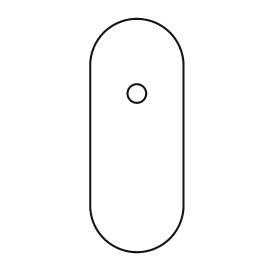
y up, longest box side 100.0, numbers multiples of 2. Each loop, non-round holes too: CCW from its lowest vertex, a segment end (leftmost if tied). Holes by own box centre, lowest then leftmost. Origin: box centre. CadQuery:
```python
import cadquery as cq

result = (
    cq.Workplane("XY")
    .moveTo(-20.0, -30.0)
    .threePointArc((0.0, -50.0), (20.0, -30.0))
    .lineTo(20.0, 30.0)
    .threePointArc((0.0, 50.0), (-20.0, 30.0))
    .close()
    .moveTo(0.0, 18.0)
    .circle(4.0)
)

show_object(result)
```